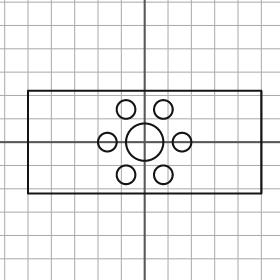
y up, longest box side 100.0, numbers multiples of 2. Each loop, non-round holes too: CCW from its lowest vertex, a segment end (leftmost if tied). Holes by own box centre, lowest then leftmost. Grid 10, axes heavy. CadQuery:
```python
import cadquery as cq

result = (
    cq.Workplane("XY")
    .moveTo(-50.0, -22.0)
    .lineTo(50.0, -22.0)
    .lineTo(50.0, 22.0)
    .lineTo(-50.0, 22.0)
    .close()
    .moveTo(-8.0, -14.0)
    .circle(4.0)
    .moveTo(8.0, -14.0)
    .circle(4.0)
    .moveTo(-16.0, 0.0)
    .circle(4.0)
    .moveTo(0.0, 0.0)
    .circle(8.0)
    .moveTo(16.0, 0.0)
    .circle(4.0)
    .moveTo(-8.0, 14.0)
    .circle(4.0)
    .moveTo(8.0, 14.0)
    .circle(4.0)
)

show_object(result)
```